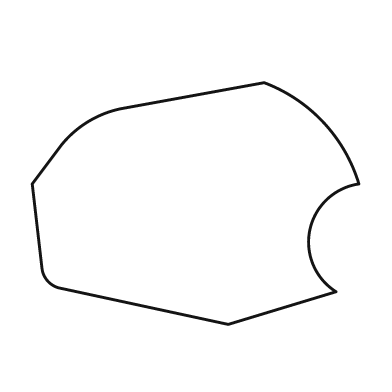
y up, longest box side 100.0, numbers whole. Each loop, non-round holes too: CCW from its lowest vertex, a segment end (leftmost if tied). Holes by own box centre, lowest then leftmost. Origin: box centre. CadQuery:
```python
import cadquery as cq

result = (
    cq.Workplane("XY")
    .moveTo(10.0, -37.0)
    .lineTo(43.0, -27.0)
    .threePointArc((35.0, -8.0), (50.0, 6.0))
    .threePointArc((39.0, 25.0), (21.0, 37.0))
    .lineTo(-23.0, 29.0)
    .threePointArc((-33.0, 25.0), (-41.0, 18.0))
    .lineTo(-50.0, 6.0)
    .lineTo(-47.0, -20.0)
    .threePointArc((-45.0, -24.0), (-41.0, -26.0))
    .close()
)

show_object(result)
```